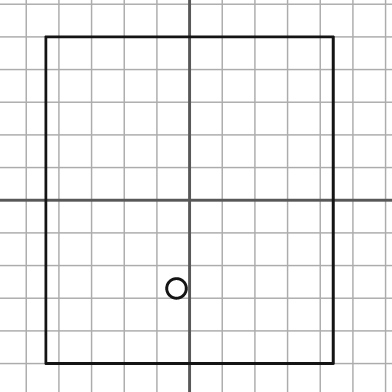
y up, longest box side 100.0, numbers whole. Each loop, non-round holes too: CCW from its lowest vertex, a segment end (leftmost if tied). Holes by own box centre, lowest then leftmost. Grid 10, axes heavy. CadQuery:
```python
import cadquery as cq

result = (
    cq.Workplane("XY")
    .moveTo(-44.0, -50.0)
    .lineTo(44.0, -50.0)
    .lineTo(44.0, 50.0)
    .lineTo(-44.0, 50.0)
    .close()
    .moveTo(-4.0, -27.0)
    .circle(3.0)
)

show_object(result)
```